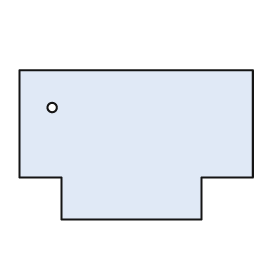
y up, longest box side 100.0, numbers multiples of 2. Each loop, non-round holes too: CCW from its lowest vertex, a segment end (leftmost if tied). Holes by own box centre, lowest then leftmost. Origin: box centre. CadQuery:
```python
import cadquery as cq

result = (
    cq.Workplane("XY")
    .moveTo(-32.0, -32.0)
    .lineTo(28.0, -32.0)
    .lineTo(28.0, -14.0)
    .lineTo(50.0, -14.0)
    .lineTo(50.0, 32.0)
    .lineTo(-50.0, 32.0)
    .lineTo(-50.0, -14.0)
    .lineTo(-32.0, -14.0)
    .close()
    .moveTo(-36.0, 16.0)
    .circle(2.0)
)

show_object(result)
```